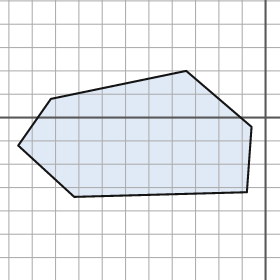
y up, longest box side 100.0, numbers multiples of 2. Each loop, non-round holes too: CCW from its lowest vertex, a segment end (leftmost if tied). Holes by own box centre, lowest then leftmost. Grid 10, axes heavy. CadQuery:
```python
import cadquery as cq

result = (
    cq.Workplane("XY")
    .moveTo(-82.0, -34.0)
    .lineTo(-8.0, -32.0)
    .lineTo(-6.0, -4.0)
    .lineTo(-34.0, 20.0)
    .lineTo(-92.0, 8.0)
    .lineTo(-106.0, -12.0)
    .close()
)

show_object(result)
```